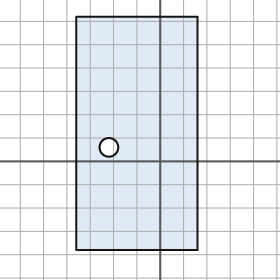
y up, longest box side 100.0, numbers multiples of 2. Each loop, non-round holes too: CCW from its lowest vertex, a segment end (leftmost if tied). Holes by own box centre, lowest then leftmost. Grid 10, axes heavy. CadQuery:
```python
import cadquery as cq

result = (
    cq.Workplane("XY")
    .moveTo(-36.0, -38.0)
    .lineTo(16.0, -38.0)
    .lineTo(16.0, 62.0)
    .lineTo(-36.0, 62.0)
    .close()
    .moveTo(-22.0, 6.0)
    .circle(4.0)
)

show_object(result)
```